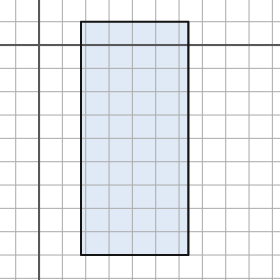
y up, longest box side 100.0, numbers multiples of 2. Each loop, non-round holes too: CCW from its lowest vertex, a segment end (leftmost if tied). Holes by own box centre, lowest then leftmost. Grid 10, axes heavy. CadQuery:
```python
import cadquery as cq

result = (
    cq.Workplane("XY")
    .moveTo(18.0, -90.0)
    .lineTo(64.0, -90.0)
    .lineTo(64.0, 10.0)
    .lineTo(18.0, 10.0)
    .close()
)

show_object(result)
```